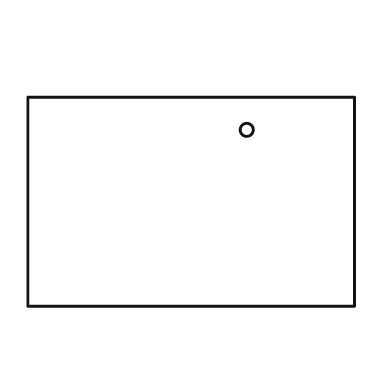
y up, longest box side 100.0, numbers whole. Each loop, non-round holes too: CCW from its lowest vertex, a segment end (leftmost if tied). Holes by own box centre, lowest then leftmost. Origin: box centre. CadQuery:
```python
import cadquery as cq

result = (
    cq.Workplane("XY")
    .moveTo(-50.0, -32.0)
    .lineTo(50.0, -32.0)
    .lineTo(50.0, 32.0)
    .lineTo(-50.0, 32.0)
    .close()
    .moveTo(17.0, 22.0)
    .circle(2.0)
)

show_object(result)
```